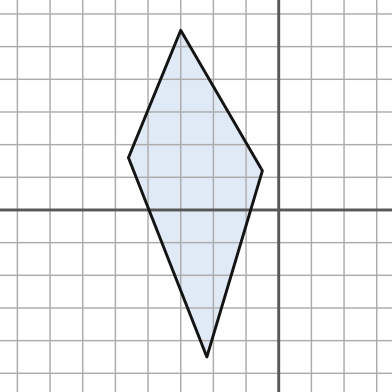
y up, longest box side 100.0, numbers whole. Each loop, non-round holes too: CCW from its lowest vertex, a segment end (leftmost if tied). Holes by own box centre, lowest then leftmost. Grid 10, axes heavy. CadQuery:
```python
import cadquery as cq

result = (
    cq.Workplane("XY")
    .moveTo(-22.0, -45.0)
    .lineTo(-5.0, 12.0)
    .lineTo(-30.0, 55.0)
    .lineTo(-46.0, 16.0)
    .close()
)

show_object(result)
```